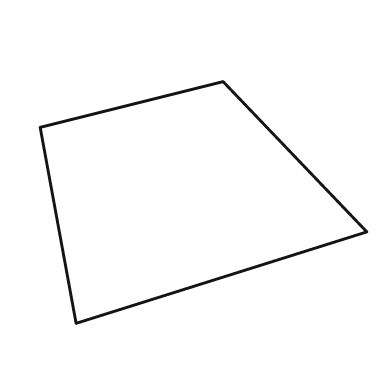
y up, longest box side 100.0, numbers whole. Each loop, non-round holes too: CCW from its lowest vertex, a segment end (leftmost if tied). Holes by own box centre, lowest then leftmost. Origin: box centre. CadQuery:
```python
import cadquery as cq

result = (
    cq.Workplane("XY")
    .moveTo(-39.0, -37.0)
    .lineTo(50.0, -9.0)
    .lineTo(6.0, 37.0)
    .lineTo(-50.0, 23.0)
    .close()
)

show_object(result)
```